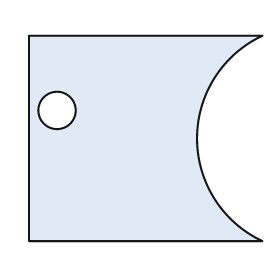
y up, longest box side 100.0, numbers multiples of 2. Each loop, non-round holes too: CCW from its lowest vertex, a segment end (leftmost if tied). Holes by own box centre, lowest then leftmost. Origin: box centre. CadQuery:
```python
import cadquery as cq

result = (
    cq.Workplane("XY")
    .moveTo(-50.0, -44.0)
    .lineTo(50.0, -44.0)
    .threePointArc((22.0, 0.0), (50.0, 44.0))
    .lineTo(-50.0, 44.0)
    .close()
    .moveTo(-38.0, 12.0)
    .circle(8.0)
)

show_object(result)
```